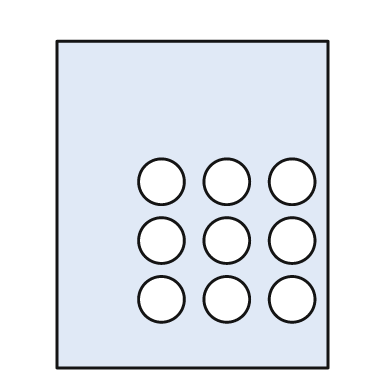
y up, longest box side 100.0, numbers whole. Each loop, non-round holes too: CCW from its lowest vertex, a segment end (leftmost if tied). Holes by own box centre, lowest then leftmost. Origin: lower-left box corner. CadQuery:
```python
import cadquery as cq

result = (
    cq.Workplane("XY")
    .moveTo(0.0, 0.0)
    .lineTo(83.0, 0.0)
    .lineTo(83.0, 100.0)
    .lineTo(0.0, 100.0)
    .close()
    .moveTo(32.0, 21.0)
    .circle(7.0)
    .moveTo(52.0, 21.0)
    .circle(7.0)
    .moveTo(72.0, 21.0)
    .circle(7.0)
    .moveTo(32.0, 39.0)
    .circle(7.0)
    .moveTo(52.0, 39.0)
    .circle(7.0)
    .moveTo(72.0, 39.0)
    .circle(7.0)
    .moveTo(32.0, 57.0)
    .circle(7.0)
    .moveTo(52.0, 57.0)
    .circle(7.0)
    .moveTo(72.0, 57.0)
    .circle(7.0)
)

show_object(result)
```